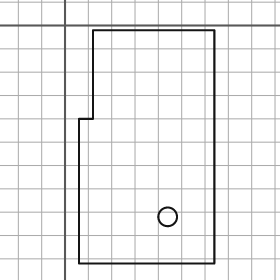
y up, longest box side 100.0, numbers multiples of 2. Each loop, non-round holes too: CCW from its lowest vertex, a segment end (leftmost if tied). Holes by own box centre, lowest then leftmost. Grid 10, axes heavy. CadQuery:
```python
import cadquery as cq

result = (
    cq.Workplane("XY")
    .moveTo(6.0, -102.0)
    .lineTo(64.0, -102.0)
    .lineTo(64.0, -2.0)
    .lineTo(12.0, -2.0)
    .lineTo(12.0, -40.0)
    .lineTo(6.0, -40.0)
    .close()
    .moveTo(44.0, -82.0)
    .circle(4.0)
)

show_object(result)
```